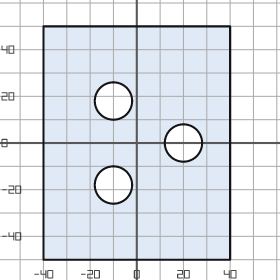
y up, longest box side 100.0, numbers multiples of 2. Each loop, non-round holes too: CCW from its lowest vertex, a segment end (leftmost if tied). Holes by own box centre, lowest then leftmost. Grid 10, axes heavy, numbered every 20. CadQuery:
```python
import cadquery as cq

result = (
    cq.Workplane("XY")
    .moveTo(-40.0, -50.0)
    .lineTo(40.0, -50.0)
    .lineTo(40.0, 50.0)
    .lineTo(-40.0, 50.0)
    .close()
    .moveTo(-10.0, -18.0)
    .circle(8.0)
    .moveTo(20.0, 0.0)
    .circle(8.0)
    .moveTo(-10.0, 18.0)
    .circle(8.0)
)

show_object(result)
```